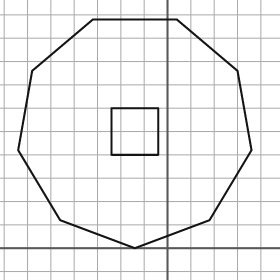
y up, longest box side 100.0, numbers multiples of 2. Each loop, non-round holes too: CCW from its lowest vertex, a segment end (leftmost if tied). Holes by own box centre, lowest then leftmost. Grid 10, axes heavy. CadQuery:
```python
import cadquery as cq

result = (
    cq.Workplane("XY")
    .moveTo(-14.0, 0.0)
    .lineTo(18.0, 12.0)
    .lineTo(36.0, 42.0)
    .lineTo(30.0, 76.0)
    .lineTo(4.0, 98.0)
    .lineTo(-32.0, 98.0)
    .lineTo(-58.0, 76.0)
    .lineTo(-64.0, 42.0)
    .lineTo(-46.0, 12.0)
    .close()
    .moveTo(-24.0, 40.0)
    .lineTo(-4.0, 40.0)
    .lineTo(-4.0, 60.0)
    .lineTo(-24.0, 60.0)
    .close()
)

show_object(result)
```